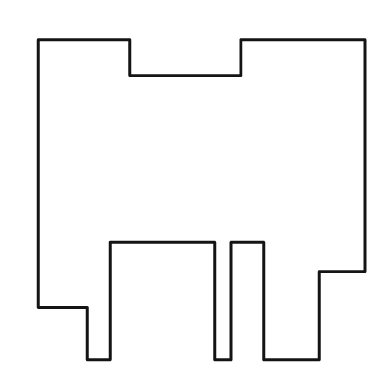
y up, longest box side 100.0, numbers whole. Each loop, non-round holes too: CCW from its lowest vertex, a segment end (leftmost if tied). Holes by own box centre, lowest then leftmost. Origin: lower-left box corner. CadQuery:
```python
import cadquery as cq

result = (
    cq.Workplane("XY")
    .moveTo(15.0, 0.0)
    .lineTo(22.0, 0.0)
    .lineTo(22.0, 36.0)
    .lineTo(54.0, 36.0)
    .lineTo(54.0, 0.0)
    .lineTo(59.0, 0.0)
    .lineTo(59.0, 36.0)
    .lineTo(69.0, 36.0)
    .lineTo(69.0, 0.0)
    .lineTo(86.0, 0.0)
    .lineTo(86.0, 27.0)
    .lineTo(100.0, 27.0)
    .lineTo(100.0, 98.0)
    .lineTo(62.0, 98.0)
    .lineTo(62.0, 87.0)
    .lineTo(28.0, 87.0)
    .lineTo(28.0, 98.0)
    .lineTo(0.0, 98.0)
    .lineTo(0.0, 16.0)
    .lineTo(15.0, 16.0)
    .close()
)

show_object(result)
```